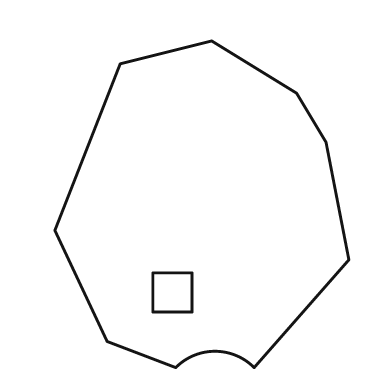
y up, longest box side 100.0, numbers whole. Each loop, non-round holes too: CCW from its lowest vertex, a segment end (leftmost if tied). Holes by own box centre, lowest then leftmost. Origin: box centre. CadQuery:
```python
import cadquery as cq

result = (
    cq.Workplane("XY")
    .moveTo(-8.0, -50.0)
    .threePointArc((4.0, -45.0), (16.0, -50.0))
    .lineTo(45.0, -17.0)
    .lineTo(38.0, 19.0)
    .lineTo(29.0, 34.0)
    .lineTo(3.0, 50.0)
    .lineTo(-25.0, 43.0)
    .lineTo(-45.0, -8.0)
    .lineTo(-29.0, -42.0)
    .close()
    .moveTo(-15.0, -33.0)
    .lineTo(-3.0, -33.0)
    .lineTo(-3.0, -21.0)
    .lineTo(-15.0, -21.0)
    .close()
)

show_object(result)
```